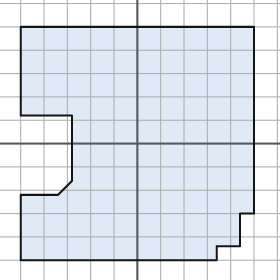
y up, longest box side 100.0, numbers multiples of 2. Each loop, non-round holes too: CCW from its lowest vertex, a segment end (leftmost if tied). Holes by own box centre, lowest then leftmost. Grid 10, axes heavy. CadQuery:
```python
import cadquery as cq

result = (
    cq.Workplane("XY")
    .moveTo(-50.0, -50.0)
    .lineTo(34.0, -50.0)
    .lineTo(34.0, -44.0)
    .lineTo(44.0, -44.0)
    .lineTo(44.0, -30.0)
    .lineTo(50.0, -30.0)
    .lineTo(50.0, 50.0)
    .lineTo(-50.0, 50.0)
    .lineTo(-50.0, 12.0)
    .lineTo(-28.0, 12.0)
    .lineTo(-28.0, -16.0)
    .lineTo(-34.0, -22.0)
    .lineTo(-50.0, -22.0)
    .close()
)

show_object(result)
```